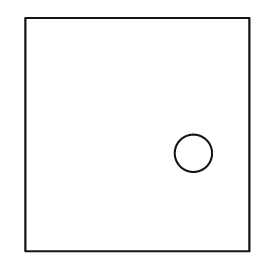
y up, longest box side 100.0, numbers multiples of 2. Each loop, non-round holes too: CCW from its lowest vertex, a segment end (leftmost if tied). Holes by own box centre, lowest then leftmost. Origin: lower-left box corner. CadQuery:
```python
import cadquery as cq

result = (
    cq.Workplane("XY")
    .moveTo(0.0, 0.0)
    .lineTo(96.0, 0.0)
    .lineTo(96.0, 100.0)
    .lineTo(0.0, 100.0)
    .close()
    .moveTo(72.0, 42.0)
    .circle(8.0)
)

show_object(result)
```